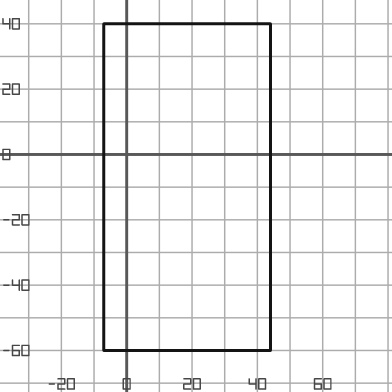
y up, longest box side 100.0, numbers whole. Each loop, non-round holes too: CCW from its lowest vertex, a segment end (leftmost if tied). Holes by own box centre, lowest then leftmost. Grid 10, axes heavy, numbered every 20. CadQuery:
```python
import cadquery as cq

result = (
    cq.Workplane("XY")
    .moveTo(-7.0, -60.0)
    .lineTo(44.0, -60.0)
    .lineTo(44.0, 40.0)
    .lineTo(-7.0, 40.0)
    .close()
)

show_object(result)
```